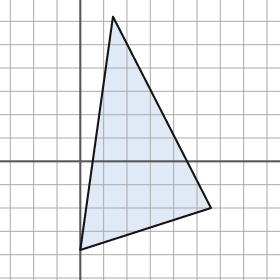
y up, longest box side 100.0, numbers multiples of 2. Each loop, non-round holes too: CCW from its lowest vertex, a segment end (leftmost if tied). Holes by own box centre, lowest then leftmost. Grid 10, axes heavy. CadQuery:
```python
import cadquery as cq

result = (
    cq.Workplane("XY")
    .moveTo(0.0, -38.0)
    .lineTo(56.0, -20.0)
    .lineTo(14.0, 62.0)
    .close()
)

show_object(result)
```